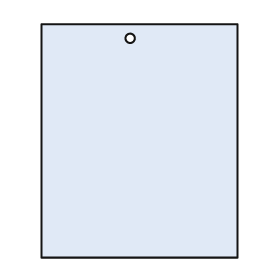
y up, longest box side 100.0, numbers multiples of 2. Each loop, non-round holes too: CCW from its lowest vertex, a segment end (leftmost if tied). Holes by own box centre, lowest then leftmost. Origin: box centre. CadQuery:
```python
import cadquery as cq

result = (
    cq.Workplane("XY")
    .moveTo(-42.0, -50.0)
    .lineTo(42.0, -50.0)
    .lineTo(42.0, 50.0)
    .lineTo(-42.0, 50.0)
    .close()
    .moveTo(-4.0, 44.0)
    .circle(2.0)
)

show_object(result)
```